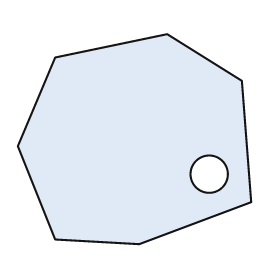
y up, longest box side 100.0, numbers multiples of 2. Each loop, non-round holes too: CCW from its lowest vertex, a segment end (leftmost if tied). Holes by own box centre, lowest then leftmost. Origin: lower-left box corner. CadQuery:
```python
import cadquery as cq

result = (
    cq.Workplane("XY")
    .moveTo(52.0, 0.0)
    .lineTo(100.0, 18.0)
    .lineTo(96.0, 70.0)
    .lineTo(64.0, 90.0)
    .lineTo(16.0, 80.0)
    .lineTo(0.0, 42.0)
    .lineTo(16.0, 2.0)
    .close()
    .moveTo(82.0, 30.0)
    .circle(8.0)
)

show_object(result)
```